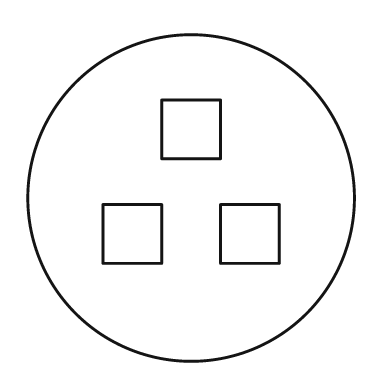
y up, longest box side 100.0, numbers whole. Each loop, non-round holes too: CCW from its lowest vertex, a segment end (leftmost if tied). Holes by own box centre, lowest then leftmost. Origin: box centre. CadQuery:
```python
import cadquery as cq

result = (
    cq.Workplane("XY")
    .moveTo(0.0, 0.0)
    .circle(50.0)
    .moveTo(-27.0, -20.0)
    .lineTo(-9.0, -20.0)
    .lineTo(-9.0, -2.0)
    .lineTo(-27.0, -2.0)
    .close()
    .moveTo(9.0, -20.0)
    .lineTo(27.0, -20.0)
    .lineTo(27.0, -2.0)
    .lineTo(9.0, -2.0)
    .close()
    .moveTo(-9.0, 12.0)
    .lineTo(9.0, 12.0)
    .lineTo(9.0, 30.0)
    .lineTo(-9.0, 30.0)
    .close()
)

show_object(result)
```